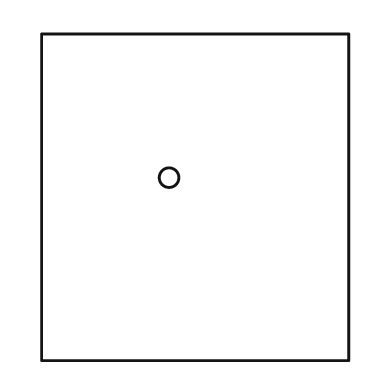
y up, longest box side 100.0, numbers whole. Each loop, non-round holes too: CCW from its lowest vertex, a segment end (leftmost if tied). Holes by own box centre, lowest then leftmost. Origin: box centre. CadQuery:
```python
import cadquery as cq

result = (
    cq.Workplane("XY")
    .moveTo(-47.0, -50.0)
    .lineTo(47.0, -50.0)
    .lineTo(47.0, 50.0)
    .lineTo(-47.0, 50.0)
    .close()
    .moveTo(-8.0, 6.0)
    .circle(3.0)
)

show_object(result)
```